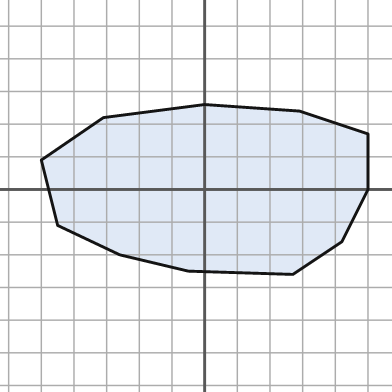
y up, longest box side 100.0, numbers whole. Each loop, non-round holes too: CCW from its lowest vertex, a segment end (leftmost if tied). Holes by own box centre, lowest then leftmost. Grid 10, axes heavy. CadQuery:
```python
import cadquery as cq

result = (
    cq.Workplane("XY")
    .moveTo(27.0, -26.0)
    .lineTo(42.0, -16.0)
    .lineTo(50.0, 0.0)
    .lineTo(50.0, 17.0)
    .lineTo(29.0, 24.0)
    .lineTo(0.0, 26.0)
    .lineTo(-31.0, 22.0)
    .lineTo(-50.0, 9.0)
    .lineTo(-45.0, -11.0)
    .lineTo(-26.0, -20.0)
    .lineTo(-5.0, -25.0)
    .close()
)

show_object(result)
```